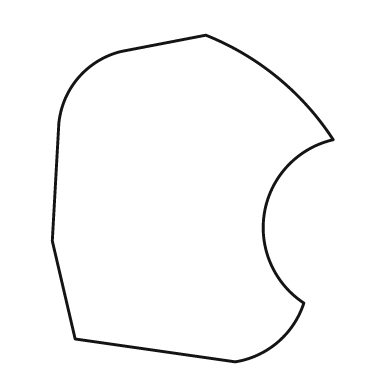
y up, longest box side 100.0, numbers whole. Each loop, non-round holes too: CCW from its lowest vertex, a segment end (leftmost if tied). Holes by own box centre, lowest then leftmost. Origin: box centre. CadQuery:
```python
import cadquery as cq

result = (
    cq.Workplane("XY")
    .moveTo(13.0, -50.0)
    .threePointArc((26.0, -44.0), (34.0, -32.0))
    .threePointArc((22.0, -4.0), (43.0, 18.0))
    .threePointArc((26.0, 37.0), (4.0, 50.0))
    .lineTo(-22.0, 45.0)
    .threePointArc((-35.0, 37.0), (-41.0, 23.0))
    .lineTo(-43.0, -13.0)
    .lineTo(-36.0, -43.0)
    .close()
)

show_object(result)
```